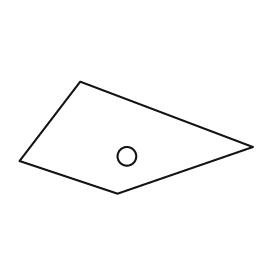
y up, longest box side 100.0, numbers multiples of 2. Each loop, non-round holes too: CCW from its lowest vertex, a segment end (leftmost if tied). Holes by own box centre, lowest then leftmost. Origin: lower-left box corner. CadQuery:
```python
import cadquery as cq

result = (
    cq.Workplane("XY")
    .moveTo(42.0, 0.0)
    .lineTo(100.0, 20.0)
    .lineTo(26.0, 48.0)
    .lineTo(0.0, 14.0)
    .close()
    .moveTo(46.0, 16.0)
    .circle(4.0)
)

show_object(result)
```